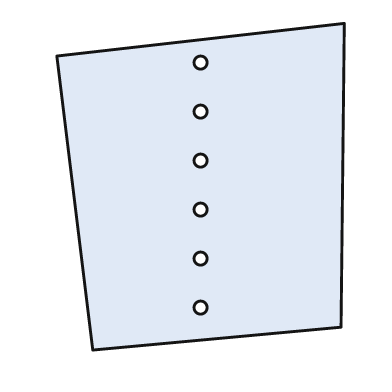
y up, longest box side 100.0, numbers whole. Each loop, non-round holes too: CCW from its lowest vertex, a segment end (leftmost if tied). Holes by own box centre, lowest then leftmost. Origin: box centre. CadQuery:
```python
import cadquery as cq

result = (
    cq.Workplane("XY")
    .moveTo(-33.0, -50.0)
    .lineTo(43.0, -43.0)
    .lineTo(44.0, 50.0)
    .lineTo(-44.0, 40.0)
    .close()
    .moveTo(0.0, -37.0)
    .circle(2.0)
    .moveTo(0.0, -22.0)
    .circle(2.0)
    .moveTo(0.0, -7.0)
    .circle(2.0)
    .moveTo(0.0, 8.0)
    .circle(2.0)
    .moveTo(0.0, 23.0)
    .circle(2.0)
    .moveTo(0.0, 38.0)
    .circle(2.0)
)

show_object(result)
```